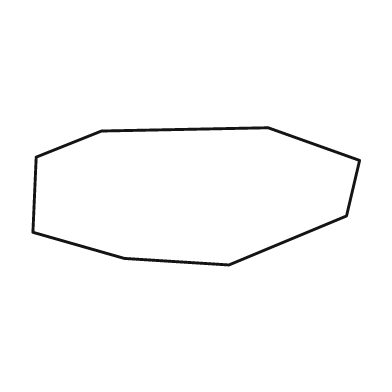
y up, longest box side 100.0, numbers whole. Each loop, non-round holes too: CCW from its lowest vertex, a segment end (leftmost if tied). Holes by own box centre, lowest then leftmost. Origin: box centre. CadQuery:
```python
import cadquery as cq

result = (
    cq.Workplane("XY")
    .moveTo(10.0, -21.0)
    .lineTo(46.0, -6.0)
    .lineTo(50.0, 11.0)
    .lineTo(22.0, 21.0)
    .lineTo(-29.0, 20.0)
    .lineTo(-49.0, 12.0)
    .lineTo(-50.0, -11.0)
    .lineTo(-22.0, -19.0)
    .close()
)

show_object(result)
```